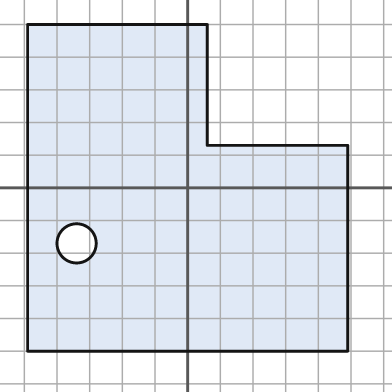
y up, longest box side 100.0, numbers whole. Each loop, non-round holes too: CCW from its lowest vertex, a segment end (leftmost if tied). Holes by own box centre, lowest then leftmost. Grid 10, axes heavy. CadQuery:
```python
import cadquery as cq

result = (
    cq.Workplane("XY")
    .moveTo(-49.0, -50.0)
    .lineTo(49.0, -50.0)
    .lineTo(49.0, 13.0)
    .lineTo(6.0, 13.0)
    .lineTo(6.0, 50.0)
    .lineTo(-49.0, 50.0)
    .close()
    .moveTo(-34.0, -17.0)
    .circle(6.0)
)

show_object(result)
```